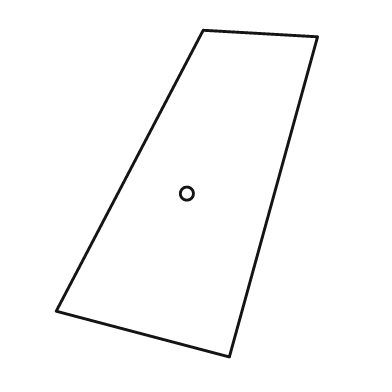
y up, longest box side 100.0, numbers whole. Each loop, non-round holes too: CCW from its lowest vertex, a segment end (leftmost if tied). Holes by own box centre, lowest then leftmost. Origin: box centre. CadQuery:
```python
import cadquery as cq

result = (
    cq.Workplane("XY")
    .moveTo(13.0, -50.0)
    .lineTo(40.0, 48.0)
    .lineTo(5.0, 50.0)
    .lineTo(-40.0, -36.0)
    .close()
    .moveTo(0.0, 0.0)
    .circle(2.0)
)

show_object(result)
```